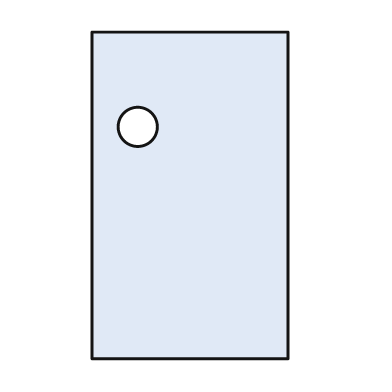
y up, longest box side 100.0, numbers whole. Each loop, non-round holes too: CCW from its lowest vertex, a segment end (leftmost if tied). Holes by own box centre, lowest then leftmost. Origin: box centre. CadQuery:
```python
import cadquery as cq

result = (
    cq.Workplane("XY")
    .moveTo(-30.0, -50.0)
    .lineTo(30.0, -50.0)
    .lineTo(30.0, 50.0)
    .lineTo(-30.0, 50.0)
    .close()
    .moveTo(-16.0, 21.0)
    .circle(6.0)
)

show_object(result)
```